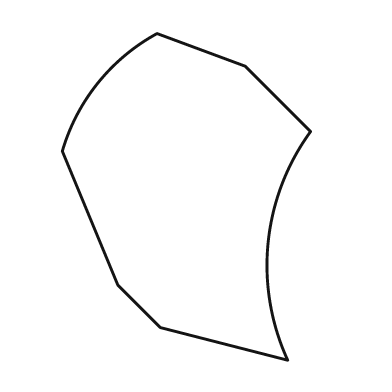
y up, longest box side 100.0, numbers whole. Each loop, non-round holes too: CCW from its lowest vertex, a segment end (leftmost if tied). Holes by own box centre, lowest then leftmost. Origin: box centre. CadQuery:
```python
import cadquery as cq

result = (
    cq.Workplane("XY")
    .moveTo(31.0, -50.0)
    .threePointArc((25.0, -14.0), (38.0, 20.0))
    .lineTo(18.0, 40.0)
    .lineTo(-9.0, 50.0)
    .threePointArc((-27.0, 35.0), (-38.0, 14.0))
    .lineTo(-21.0, -27.0)
    .lineTo(-8.0, -40.0)
    .close()
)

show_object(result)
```